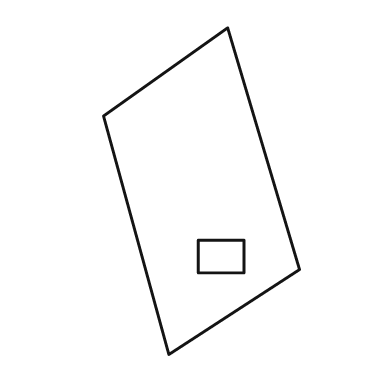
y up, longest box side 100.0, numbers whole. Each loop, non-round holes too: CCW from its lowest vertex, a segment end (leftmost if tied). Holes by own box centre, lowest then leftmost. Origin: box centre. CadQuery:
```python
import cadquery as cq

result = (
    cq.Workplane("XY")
    .moveTo(-10.0, -50.0)
    .lineTo(30.0, -24.0)
    .lineTo(8.0, 50.0)
    .lineTo(-30.0, 23.0)
    .close()
    .moveTo(-1.0, -25.0)
    .lineTo(13.0, -25.0)
    .lineTo(13.0, -15.0)
    .lineTo(-1.0, -15.0)
    .close()
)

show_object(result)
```